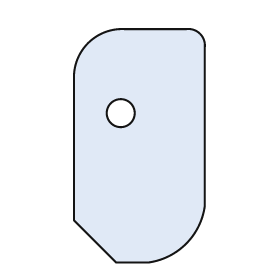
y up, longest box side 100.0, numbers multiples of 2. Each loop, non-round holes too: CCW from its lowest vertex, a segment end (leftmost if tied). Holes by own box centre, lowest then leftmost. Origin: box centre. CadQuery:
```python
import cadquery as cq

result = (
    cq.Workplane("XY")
    .moveTo(-10.0, -50.0)
    .lineTo(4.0, -50.0)
    .threePointArc((20.0, -42.0), (28.0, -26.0))
    .lineTo(28.0, 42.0)
    .threePointArc((26.0, 48.0), (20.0, 50.0))
    .lineTo(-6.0, 50.0)
    .threePointArc((-22.0, 44.0), (-28.0, 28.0))
    .lineTo(-28.0, -32.0)
    .close()
    .moveTo(-8.0, 14.0)
    .circle(6.0)
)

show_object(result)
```